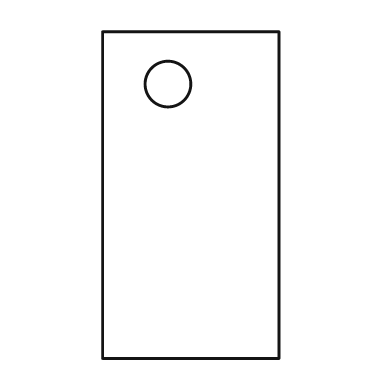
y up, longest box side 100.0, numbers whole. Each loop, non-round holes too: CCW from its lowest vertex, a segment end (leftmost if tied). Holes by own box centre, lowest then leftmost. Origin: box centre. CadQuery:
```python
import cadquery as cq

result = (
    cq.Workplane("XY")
    .moveTo(-27.0, -50.0)
    .lineTo(27.0, -50.0)
    .lineTo(27.0, 50.0)
    .lineTo(-27.0, 50.0)
    .close()
    .moveTo(-7.0, 34.0)
    .circle(7.0)
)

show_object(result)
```